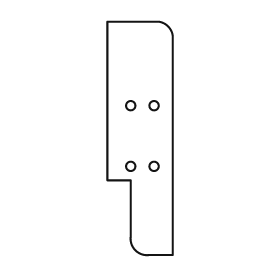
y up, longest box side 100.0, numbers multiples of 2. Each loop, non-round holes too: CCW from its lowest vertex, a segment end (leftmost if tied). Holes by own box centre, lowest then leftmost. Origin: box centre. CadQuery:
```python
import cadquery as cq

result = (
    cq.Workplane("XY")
    .moveTo(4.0, -50.0)
    .lineTo(14.0, -50.0)
    .lineTo(14.0, 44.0)
    .threePointArc((12.0, 48.0), (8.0, 50.0))
    .lineTo(-14.0, 50.0)
    .lineTo(-14.0, -18.0)
    .lineTo(-4.0, -18.0)
    .lineTo(-4.0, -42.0)
    .threePointArc((-2.0, -48.0), (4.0, -50.0))
    .close()
    .moveTo(-4.0, -12.0)
    .circle(2.0)
    .moveTo(6.0, -12.0)
    .circle(2.0)
    .moveTo(-4.0, 14.0)
    .circle(2.0)
    .moveTo(6.0, 14.0)
    .circle(2.0)
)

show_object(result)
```